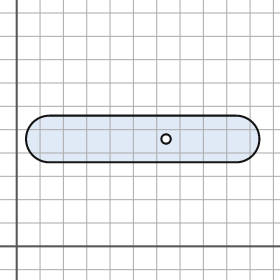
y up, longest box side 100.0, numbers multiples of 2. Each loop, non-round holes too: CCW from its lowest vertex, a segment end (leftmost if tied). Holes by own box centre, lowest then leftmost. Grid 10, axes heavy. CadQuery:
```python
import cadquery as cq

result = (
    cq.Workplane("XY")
    .moveTo(14.0, 36.0)
    .lineTo(94.0, 36.0)
    .threePointArc((104.0, 46.0), (94.0, 56.0))
    .lineTo(14.0, 56.0)
    .threePointArc((4.0, 46.0), (14.0, 36.0))
    .close()
    .moveTo(64.0, 46.0)
    .circle(2.0)
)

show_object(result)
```